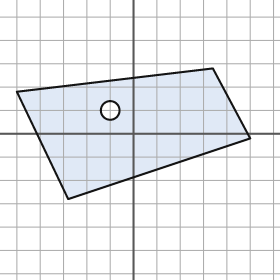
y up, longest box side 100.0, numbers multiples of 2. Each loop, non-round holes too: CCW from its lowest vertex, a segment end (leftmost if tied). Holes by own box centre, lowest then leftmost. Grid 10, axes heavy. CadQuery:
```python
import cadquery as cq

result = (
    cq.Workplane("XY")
    .moveTo(-28.0, -28.0)
    .lineTo(50.0, -2.0)
    .lineTo(34.0, 28.0)
    .lineTo(-50.0, 18.0)
    .close()
    .moveTo(-10.0, 10.0)
    .circle(4.0)
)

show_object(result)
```